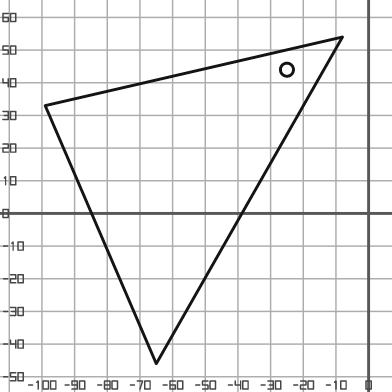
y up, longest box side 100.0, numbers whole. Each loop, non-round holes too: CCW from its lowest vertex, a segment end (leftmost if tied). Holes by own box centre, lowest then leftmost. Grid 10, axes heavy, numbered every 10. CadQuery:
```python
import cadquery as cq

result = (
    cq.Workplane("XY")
    .moveTo(-65.0, -46.0)
    .lineTo(-8.0, 54.0)
    .lineTo(-99.0, 33.0)
    .close()
    .moveTo(-25.0, 44.0)
    .circle(2.0)
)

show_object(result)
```